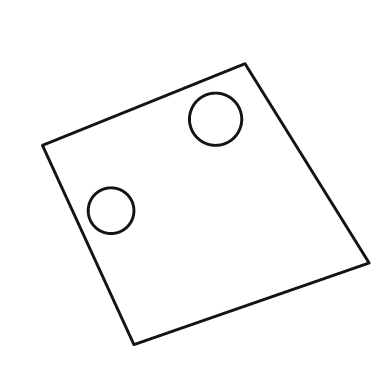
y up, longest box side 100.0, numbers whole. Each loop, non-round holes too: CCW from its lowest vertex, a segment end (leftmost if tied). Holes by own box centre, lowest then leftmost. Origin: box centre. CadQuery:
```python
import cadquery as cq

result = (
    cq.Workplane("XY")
    .moveTo(-22.0, -43.0)
    .lineTo(50.0, -18.0)
    .lineTo(12.0, 43.0)
    .lineTo(-50.0, 18.0)
    .close()
    .moveTo(-29.0, -2.0)
    .circle(7.0)
    .moveTo(3.0, 26.0)
    .circle(8.0)
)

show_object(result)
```